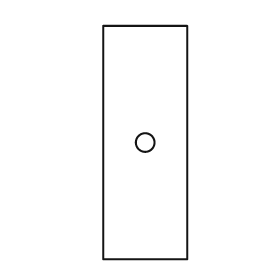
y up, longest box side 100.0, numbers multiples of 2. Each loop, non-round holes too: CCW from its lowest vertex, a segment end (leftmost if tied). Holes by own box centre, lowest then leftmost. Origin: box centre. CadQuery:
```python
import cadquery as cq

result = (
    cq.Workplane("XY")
    .moveTo(-18.0, -50.0)
    .lineTo(18.0, -50.0)
    .lineTo(18.0, 50.0)
    .lineTo(-18.0, 50.0)
    .close()
    .moveTo(0.0, 0.0)
    .circle(4.0)
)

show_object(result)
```